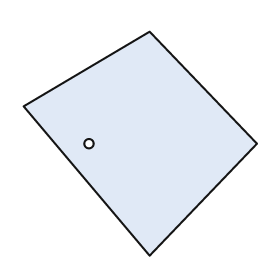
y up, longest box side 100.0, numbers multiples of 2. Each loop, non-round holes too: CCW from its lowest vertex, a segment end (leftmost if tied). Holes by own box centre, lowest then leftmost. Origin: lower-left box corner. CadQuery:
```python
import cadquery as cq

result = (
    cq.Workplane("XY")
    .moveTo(54.0, 0.0)
    .lineTo(100.0, 48.0)
    .lineTo(54.0, 96.0)
    .lineTo(0.0, 64.0)
    .close()
    .moveTo(28.0, 48.0)
    .circle(2.0)
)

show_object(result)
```